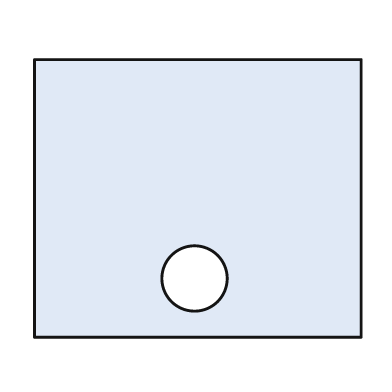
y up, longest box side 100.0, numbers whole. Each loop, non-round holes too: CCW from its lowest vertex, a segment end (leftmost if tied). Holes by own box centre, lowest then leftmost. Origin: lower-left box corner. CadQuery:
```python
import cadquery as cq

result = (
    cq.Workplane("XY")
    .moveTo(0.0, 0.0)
    .lineTo(100.0, 0.0)
    .lineTo(100.0, 85.0)
    .lineTo(0.0, 85.0)
    .close()
    .moveTo(49.0, 18.0)
    .circle(10.0)
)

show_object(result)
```